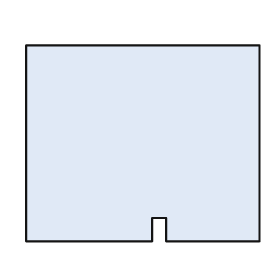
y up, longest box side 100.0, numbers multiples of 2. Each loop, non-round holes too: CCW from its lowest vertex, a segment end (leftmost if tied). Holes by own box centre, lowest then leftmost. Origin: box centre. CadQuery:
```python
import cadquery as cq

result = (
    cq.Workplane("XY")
    .moveTo(-50.0, -42.0)
    .lineTo(4.0, -42.0)
    .lineTo(4.0, -32.0)
    .lineTo(10.0, -32.0)
    .lineTo(10.0, -42.0)
    .lineTo(50.0, -42.0)
    .lineTo(50.0, 42.0)
    .lineTo(-50.0, 42.0)
    .close()
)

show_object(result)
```